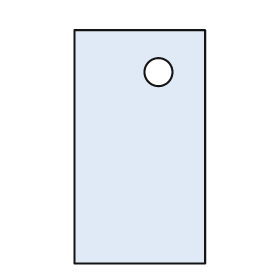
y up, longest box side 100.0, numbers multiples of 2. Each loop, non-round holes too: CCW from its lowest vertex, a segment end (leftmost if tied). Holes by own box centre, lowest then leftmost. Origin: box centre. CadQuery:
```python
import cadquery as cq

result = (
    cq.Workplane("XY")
    .moveTo(-28.0, -50.0)
    .lineTo(28.0, -50.0)
    .lineTo(28.0, 50.0)
    .lineTo(-28.0, 50.0)
    .close()
    .moveTo(8.0, 32.0)
    .circle(6.0)
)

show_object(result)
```